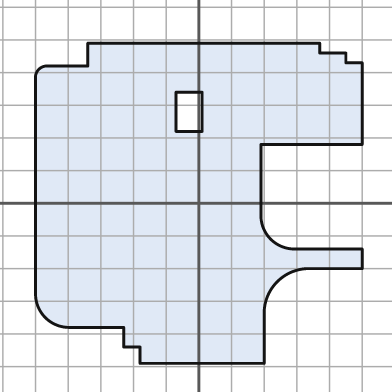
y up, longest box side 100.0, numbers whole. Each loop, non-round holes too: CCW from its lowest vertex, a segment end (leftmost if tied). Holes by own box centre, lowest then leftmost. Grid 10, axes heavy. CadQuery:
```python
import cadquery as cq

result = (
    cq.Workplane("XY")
    .moveTo(-18.0, -49.0)
    .lineTo(20.0, -49.0)
    .lineTo(20.0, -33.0)
    .threePointArc((24.0, -24.0), (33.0, -20.0))
    .lineTo(50.0, -20.0)
    .lineTo(50.0, -14.0)
    .lineTo(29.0, -14.0)
    .threePointArc((22.0, -11.0), (19.0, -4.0))
    .lineTo(19.0, 18.0)
    .lineTo(50.0, 18.0)
    .lineTo(50.0, 43.0)
    .lineTo(45.0, 43.0)
    .lineTo(45.0, 46.0)
    .lineTo(37.0, 46.0)
    .lineTo(37.0, 49.0)
    .lineTo(-34.0, 49.0)
    .lineTo(-34.0, 42.0)
    .lineTo(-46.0, 42.0)
    .threePointArc((-49.0, 41.0), (-50.0, 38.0))
    .lineTo(-50.0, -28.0)
    .threePointArc((-47.0, -35.0), (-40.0, -38.0))
    .lineTo(-23.0, -38.0)
    .lineTo(-23.0, -44.0)
    .lineTo(-18.0, -44.0)
    .close()
    .moveTo(-7.0, 22.0)
    .lineTo(1.0, 22.0)
    .lineTo(1.0, 34.0)
    .lineTo(-7.0, 34.0)
    .close()
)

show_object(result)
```